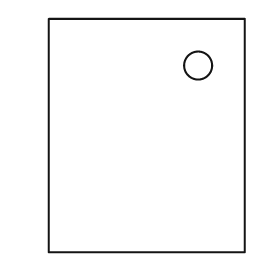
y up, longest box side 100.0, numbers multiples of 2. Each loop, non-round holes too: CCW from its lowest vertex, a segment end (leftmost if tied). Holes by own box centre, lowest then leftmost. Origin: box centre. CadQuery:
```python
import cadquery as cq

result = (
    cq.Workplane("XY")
    .moveTo(-42.0, -50.0)
    .lineTo(42.0, -50.0)
    .lineTo(42.0, 50.0)
    .lineTo(-42.0, 50.0)
    .close()
    .moveTo(22.0, 30.0)
    .circle(6.0)
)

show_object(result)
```